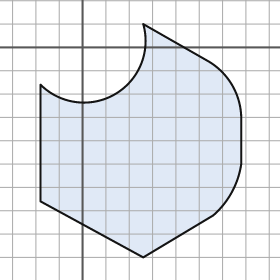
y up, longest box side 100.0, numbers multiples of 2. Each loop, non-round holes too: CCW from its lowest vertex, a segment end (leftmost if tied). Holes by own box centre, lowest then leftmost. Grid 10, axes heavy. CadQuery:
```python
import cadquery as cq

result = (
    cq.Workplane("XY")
    .moveTo(26.0, -90.0)
    .lineTo(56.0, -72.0)
    .threePointArc((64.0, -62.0), (68.0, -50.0))
    .lineTo(68.0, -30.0)
    .threePointArc((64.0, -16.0), (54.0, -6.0))
    .lineTo(26.0, 10.0)
    .threePointArc((14.0, -20.0), (-18.0, -16.0))
    .lineTo(-18.0, -66.0)
    .close()
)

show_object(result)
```